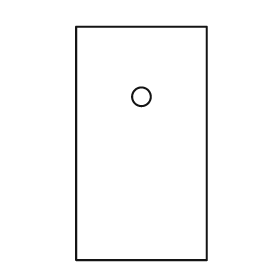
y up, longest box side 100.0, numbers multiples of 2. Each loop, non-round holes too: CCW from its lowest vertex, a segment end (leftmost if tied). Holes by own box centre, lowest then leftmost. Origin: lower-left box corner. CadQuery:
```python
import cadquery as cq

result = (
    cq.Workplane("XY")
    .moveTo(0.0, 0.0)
    .lineTo(56.0, 0.0)
    .lineTo(56.0, 100.0)
    .lineTo(0.0, 100.0)
    .close()
    .moveTo(28.0, 70.0)
    .circle(4.0)
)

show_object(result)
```